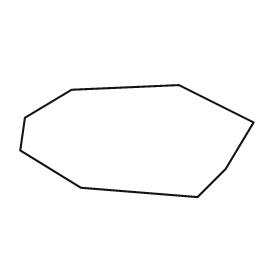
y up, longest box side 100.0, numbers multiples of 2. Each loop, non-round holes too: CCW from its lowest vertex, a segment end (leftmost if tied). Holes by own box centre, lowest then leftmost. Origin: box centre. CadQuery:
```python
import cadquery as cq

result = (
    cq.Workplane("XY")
    .moveTo(26.0, -24.0)
    .lineTo(38.0, -12.0)
    .lineTo(50.0, 8.0)
    .lineTo(18.0, 24.0)
    .lineTo(-28.0, 22.0)
    .lineTo(-48.0, 10.0)
    .lineTo(-50.0, -4.0)
    .lineTo(-24.0, -20.0)
    .close()
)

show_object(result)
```